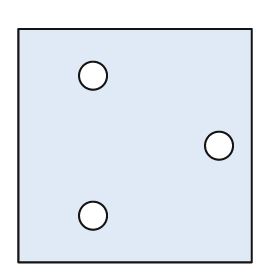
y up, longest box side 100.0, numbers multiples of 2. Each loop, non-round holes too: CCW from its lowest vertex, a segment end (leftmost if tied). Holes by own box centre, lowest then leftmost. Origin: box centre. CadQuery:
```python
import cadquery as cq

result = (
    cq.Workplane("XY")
    .moveTo(-50.0, -50.0)
    .lineTo(50.0, -50.0)
    .lineTo(50.0, 50.0)
    .lineTo(-50.0, 50.0)
    .close()
    .moveTo(-18.0, -30.0)
    .circle(6.0)
    .moveTo(36.0, 0.0)
    .circle(6.0)
    .moveTo(-18.0, 30.0)
    .circle(6.0)
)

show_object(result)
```